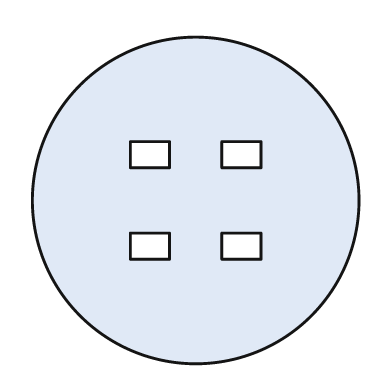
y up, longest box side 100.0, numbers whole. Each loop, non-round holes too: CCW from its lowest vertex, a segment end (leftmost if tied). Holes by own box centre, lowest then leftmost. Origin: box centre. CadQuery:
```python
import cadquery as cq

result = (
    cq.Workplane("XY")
    .moveTo(0.0, 0.0)
    .circle(50.0)
    .moveTo(-20.0, -18.0)
    .lineTo(-8.0, -18.0)
    .lineTo(-8.0, -10.0)
    .lineTo(-20.0, -10.0)
    .close()
    .moveTo(8.0, -18.0)
    .lineTo(20.0, -18.0)
    .lineTo(20.0, -10.0)
    .lineTo(8.0, -10.0)
    .close()
    .moveTo(-20.0, 10.0)
    .lineTo(-8.0, 10.0)
    .lineTo(-8.0, 18.0)
    .lineTo(-20.0, 18.0)
    .close()
    .moveTo(8.0, 10.0)
    .lineTo(20.0, 10.0)
    .lineTo(20.0, 18.0)
    .lineTo(8.0, 18.0)
    .close()
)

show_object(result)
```